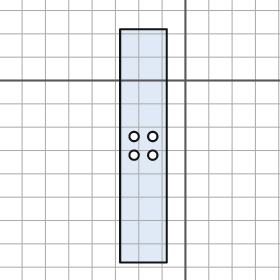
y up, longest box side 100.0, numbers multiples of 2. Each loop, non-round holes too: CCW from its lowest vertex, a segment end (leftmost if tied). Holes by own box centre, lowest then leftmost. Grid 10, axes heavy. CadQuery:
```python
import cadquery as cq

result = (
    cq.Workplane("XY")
    .moveTo(-28.0, -78.0)
    .lineTo(-8.0, -78.0)
    .lineTo(-8.0, 22.0)
    .lineTo(-28.0, 22.0)
    .close()
    .moveTo(-22.0, -32.0)
    .circle(2.0)
    .moveTo(-14.0, -32.0)
    .circle(2.0)
    .moveTo(-22.0, -24.0)
    .circle(2.0)
    .moveTo(-14.0, -24.0)
    .circle(2.0)
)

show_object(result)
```